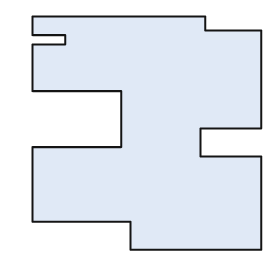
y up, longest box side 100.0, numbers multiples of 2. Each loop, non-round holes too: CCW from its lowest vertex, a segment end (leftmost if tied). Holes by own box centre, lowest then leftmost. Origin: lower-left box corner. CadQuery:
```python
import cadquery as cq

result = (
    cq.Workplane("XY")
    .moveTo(42.0, 0.0)
    .lineTo(98.0, 0.0)
    .lineTo(98.0, 40.0)
    .lineTo(72.0, 40.0)
    .lineTo(72.0, 52.0)
    .lineTo(98.0, 52.0)
    .lineTo(98.0, 94.0)
    .lineTo(74.0, 94.0)
    .lineTo(74.0, 100.0)
    .lineTo(0.0, 100.0)
    .lineTo(0.0, 92.0)
    .lineTo(14.0, 92.0)
    .lineTo(14.0, 88.0)
    .lineTo(0.0, 88.0)
    .lineTo(0.0, 68.0)
    .lineTo(38.0, 68.0)
    .lineTo(38.0, 44.0)
    .lineTo(0.0, 44.0)
    .lineTo(0.0, 12.0)
    .lineTo(42.0, 12.0)
    .close()
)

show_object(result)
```